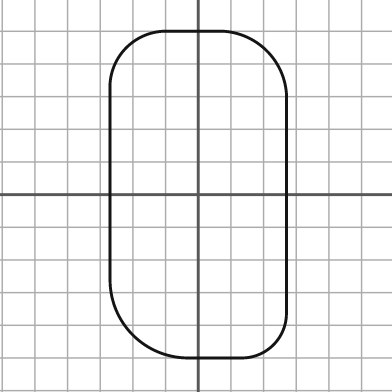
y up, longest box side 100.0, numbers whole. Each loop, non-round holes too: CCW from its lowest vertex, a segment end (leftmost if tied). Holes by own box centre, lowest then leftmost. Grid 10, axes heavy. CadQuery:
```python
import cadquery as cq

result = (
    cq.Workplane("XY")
    .moveTo(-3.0, -50.0)
    .lineTo(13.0, -50.0)
    .threePointArc((23.0, -46.0), (27.0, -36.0))
    .lineTo(27.0, 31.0)
    .threePointArc((21.0, 44.0), (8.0, 50.0))
    .lineTo(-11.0, 50.0)
    .threePointArc((-22.0, 45.0), (-27.0, 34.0))
    .lineTo(-27.0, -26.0)
    .threePointArc((-20.0, -43.0), (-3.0, -50.0))
    .close()
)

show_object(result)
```